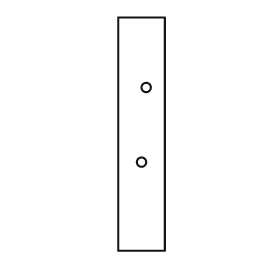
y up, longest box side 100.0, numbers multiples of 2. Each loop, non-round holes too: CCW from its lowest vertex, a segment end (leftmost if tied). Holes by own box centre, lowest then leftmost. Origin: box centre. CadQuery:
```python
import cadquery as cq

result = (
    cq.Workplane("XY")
    .moveTo(-10.0, -50.0)
    .lineTo(10.0, -50.0)
    .lineTo(10.0, 50.0)
    .lineTo(-10.0, 50.0)
    .close()
    .moveTo(0.0, -12.0)
    .circle(2.0)
    .moveTo(2.0, 20.0)
    .circle(2.0)
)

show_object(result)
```